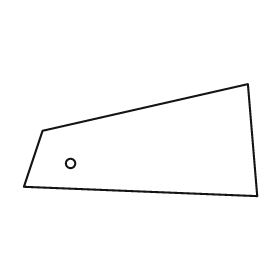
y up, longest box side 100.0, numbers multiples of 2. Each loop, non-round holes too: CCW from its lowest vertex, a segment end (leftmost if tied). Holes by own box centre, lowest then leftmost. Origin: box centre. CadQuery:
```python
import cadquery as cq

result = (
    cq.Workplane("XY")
    .moveTo(50.0, -24.0)
    .lineTo(46.0, 24.0)
    .lineTo(-42.0, 4.0)
    .lineTo(-50.0, -20.0)
    .close()
    .moveTo(-30.0, -10.0)
    .circle(2.0)
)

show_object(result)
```